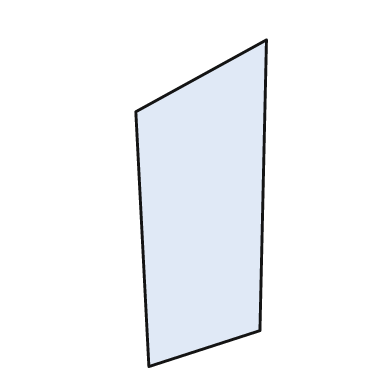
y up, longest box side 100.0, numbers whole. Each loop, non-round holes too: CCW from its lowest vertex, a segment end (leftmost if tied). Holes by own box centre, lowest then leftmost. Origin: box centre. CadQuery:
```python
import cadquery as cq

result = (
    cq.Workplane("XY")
    .moveTo(-16.0, -50.0)
    .lineTo(18.0, -39.0)
    .lineTo(20.0, 50.0)
    .lineTo(-20.0, 28.0)
    .close()
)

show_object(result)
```